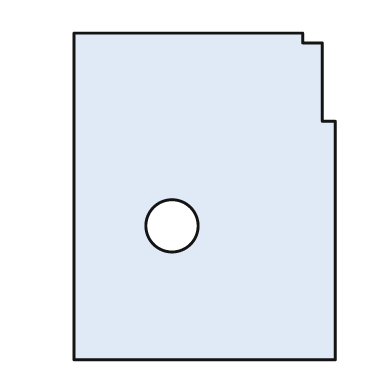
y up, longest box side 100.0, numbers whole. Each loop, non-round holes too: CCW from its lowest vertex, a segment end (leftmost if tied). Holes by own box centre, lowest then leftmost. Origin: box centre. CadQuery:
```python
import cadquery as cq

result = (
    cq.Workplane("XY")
    .moveTo(-40.0, -50.0)
    .lineTo(40.0, -50.0)
    .lineTo(40.0, 23.0)
    .lineTo(36.0, 23.0)
    .lineTo(36.0, 47.0)
    .lineTo(30.0, 47.0)
    .lineTo(30.0, 50.0)
    .lineTo(-40.0, 50.0)
    .close()
    .moveTo(-10.0, -9.0)
    .circle(8.0)
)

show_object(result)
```